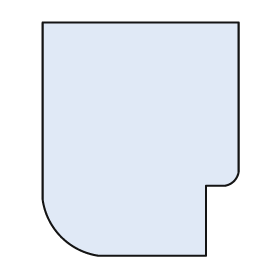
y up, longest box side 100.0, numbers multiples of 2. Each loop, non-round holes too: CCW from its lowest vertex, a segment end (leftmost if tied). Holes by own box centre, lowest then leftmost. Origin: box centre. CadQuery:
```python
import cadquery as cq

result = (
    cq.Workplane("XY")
    .moveTo(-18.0, -50.0)
    .lineTo(28.0, -50.0)
    .lineTo(28.0, -20.0)
    .lineTo(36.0, -20.0)
    .threePointArc((40.0, -18.0), (42.0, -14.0))
    .lineTo(42.0, 50.0)
    .lineTo(-42.0, 50.0)
    .lineTo(-42.0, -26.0)
    .threePointArc((-34.0, -42.0), (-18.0, -50.0))
    .close()
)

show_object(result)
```